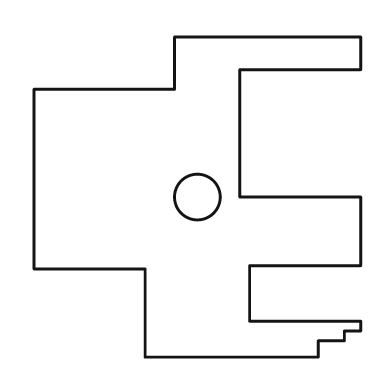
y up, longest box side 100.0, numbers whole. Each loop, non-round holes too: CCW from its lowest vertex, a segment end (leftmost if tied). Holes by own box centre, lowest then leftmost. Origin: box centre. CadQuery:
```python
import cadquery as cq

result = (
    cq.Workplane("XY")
    .moveTo(-16.0, -49.0)
    .lineTo(37.0, -49.0)
    .lineTo(37.0, -44.0)
    .lineTo(45.0, -44.0)
    .lineTo(45.0, -41.0)
    .lineTo(50.0, -41.0)
    .lineTo(50.0, -38.0)
    .lineTo(16.0, -38.0)
    .lineTo(16.0, -21.0)
    .lineTo(50.0, -21.0)
    .lineTo(50.0, 0.0)
    .lineTo(13.0, 0.0)
    .lineTo(13.0, 39.0)
    .lineTo(50.0, 39.0)
    .lineTo(50.0, 49.0)
    .lineTo(-7.0, 49.0)
    .lineTo(-7.0, 33.0)
    .lineTo(-50.0, 33.0)
    .lineTo(-50.0, -22.0)
    .lineTo(-16.0, -22.0)
    .close()
    .moveTo(0.0, 0.0)
    .circle(7.0)
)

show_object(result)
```